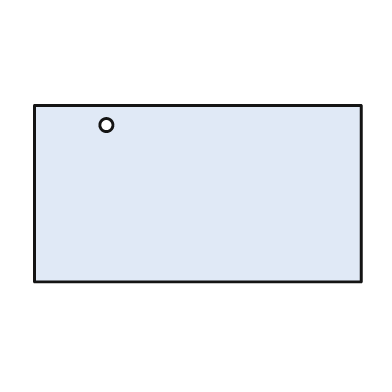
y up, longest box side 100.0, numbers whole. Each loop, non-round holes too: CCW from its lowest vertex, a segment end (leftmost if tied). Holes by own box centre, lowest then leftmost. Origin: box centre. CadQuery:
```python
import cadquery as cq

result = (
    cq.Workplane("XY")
    .moveTo(-50.0, -27.0)
    .lineTo(50.0, -27.0)
    .lineTo(50.0, 27.0)
    .lineTo(-50.0, 27.0)
    .close()
    .moveTo(-28.0, 21.0)
    .circle(2.0)
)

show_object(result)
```